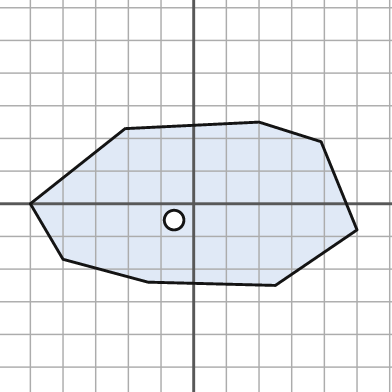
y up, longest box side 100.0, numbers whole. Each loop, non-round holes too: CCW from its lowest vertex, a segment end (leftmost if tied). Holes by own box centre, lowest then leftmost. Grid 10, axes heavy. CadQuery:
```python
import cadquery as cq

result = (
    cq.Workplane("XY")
    .moveTo(25.0, -25.0)
    .lineTo(50.0, -8.0)
    .lineTo(39.0, 19.0)
    .lineTo(20.0, 25.0)
    .lineTo(-21.0, 23.0)
    .lineTo(-50.0, 0.0)
    .lineTo(-40.0, -17.0)
    .lineTo(-14.0, -24.0)
    .close()
    .moveTo(-6.0, -5.0)
    .circle(3.0)
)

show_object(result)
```